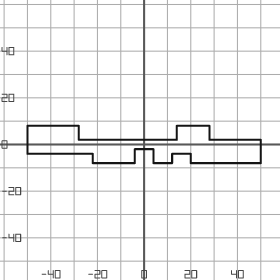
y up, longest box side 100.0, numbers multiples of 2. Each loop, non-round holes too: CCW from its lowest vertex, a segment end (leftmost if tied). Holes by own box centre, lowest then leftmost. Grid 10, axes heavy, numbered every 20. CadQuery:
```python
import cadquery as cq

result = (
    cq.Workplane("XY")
    .moveTo(-22.0, -8.0)
    .lineTo(-4.0, -8.0)
    .lineTo(-4.0, -2.0)
    .lineTo(4.0, -2.0)
    .lineTo(4.0, -8.0)
    .lineTo(12.0, -8.0)
    .lineTo(12.0, -4.0)
    .lineTo(20.0, -4.0)
    .lineTo(20.0, -8.0)
    .lineTo(50.0, -8.0)
    .lineTo(50.0, 2.0)
    .lineTo(28.0, 2.0)
    .lineTo(28.0, 8.0)
    .lineTo(14.0, 8.0)
    .lineTo(14.0, 2.0)
    .lineTo(-28.0, 2.0)
    .lineTo(-28.0, 8.0)
    .lineTo(-50.0, 8.0)
    .lineTo(-50.0, -4.0)
    .lineTo(-22.0, -4.0)
    .close()
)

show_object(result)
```